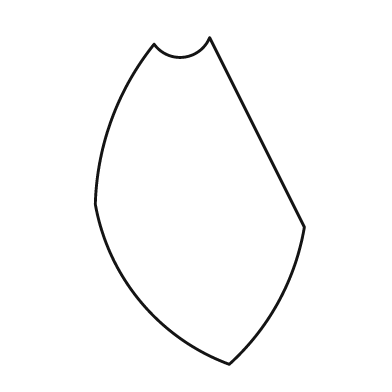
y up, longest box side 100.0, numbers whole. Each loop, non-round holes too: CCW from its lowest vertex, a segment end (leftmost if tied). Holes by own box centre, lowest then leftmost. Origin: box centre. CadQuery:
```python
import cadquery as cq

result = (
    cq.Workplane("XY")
    .moveTo(9.0, -50.0)
    .threePointArc((24.0, -31.0), (32.0, -8.0))
    .lineTo(3.0, 50.0)
    .threePointArc((-5.0, 44.0), (-14.0, 48.0))
    .threePointArc((-27.0, 25.0), (-32.0, -1.0))
    .threePointArc((-18.0, -31.0), (9.0, -50.0))
    .close()
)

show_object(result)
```